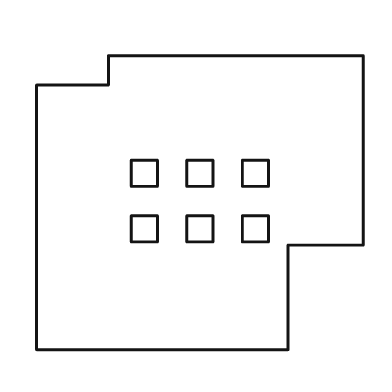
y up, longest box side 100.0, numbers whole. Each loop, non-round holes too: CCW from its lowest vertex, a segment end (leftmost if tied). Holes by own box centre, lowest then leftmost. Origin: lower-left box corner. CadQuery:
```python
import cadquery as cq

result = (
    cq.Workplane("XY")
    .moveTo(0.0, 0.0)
    .lineTo(77.0, 0.0)
    .lineTo(77.0, 32.0)
    .lineTo(100.0, 32.0)
    .lineTo(100.0, 90.0)
    .lineTo(22.0, 90.0)
    .lineTo(22.0, 81.0)
    .lineTo(0.0, 81.0)
    .close()
    .moveTo(29.0, 33.0)
    .lineTo(37.0, 33.0)
    .lineTo(37.0, 41.0)
    .lineTo(29.0, 41.0)
    .close()
    .moveTo(46.0, 33.0)
    .lineTo(54.0, 33.0)
    .lineTo(54.0, 41.0)
    .lineTo(46.0, 41.0)
    .close()
    .moveTo(63.0, 33.0)
    .lineTo(71.0, 33.0)
    .lineTo(71.0, 41.0)
    .lineTo(63.0, 41.0)
    .close()
    .moveTo(29.0, 50.0)
    .lineTo(37.0, 50.0)
    .lineTo(37.0, 58.0)
    .lineTo(29.0, 58.0)
    .close()
    .moveTo(46.0, 50.0)
    .lineTo(54.0, 50.0)
    .lineTo(54.0, 58.0)
    .lineTo(46.0, 58.0)
    .close()
    .moveTo(63.0, 50.0)
    .lineTo(71.0, 50.0)
    .lineTo(71.0, 58.0)
    .lineTo(63.0, 58.0)
    .close()
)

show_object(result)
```